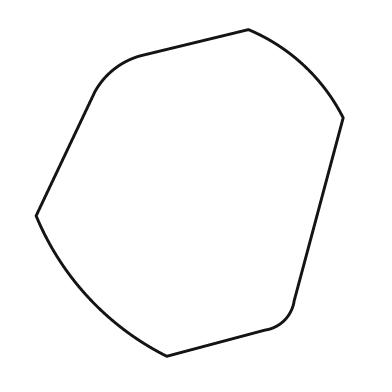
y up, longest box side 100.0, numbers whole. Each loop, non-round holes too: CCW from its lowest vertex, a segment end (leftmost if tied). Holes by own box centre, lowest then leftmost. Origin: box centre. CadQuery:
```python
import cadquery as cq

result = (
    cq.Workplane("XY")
    .moveTo(-7.0, -50.0)
    .lineTo(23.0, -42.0)
    .threePointArc((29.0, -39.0), (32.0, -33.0))
    .lineTo(47.0, 23.0)
    .threePointArc((35.0, 39.0), (18.0, 50.0))
    .lineTo(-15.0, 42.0)
    .threePointArc((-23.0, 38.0), (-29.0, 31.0))
    .lineTo(-47.0, -7.0)
    .threePointArc((-31.0, -32.0), (-7.0, -50.0))
    .close()
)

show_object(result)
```